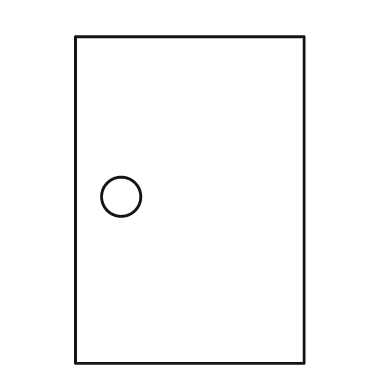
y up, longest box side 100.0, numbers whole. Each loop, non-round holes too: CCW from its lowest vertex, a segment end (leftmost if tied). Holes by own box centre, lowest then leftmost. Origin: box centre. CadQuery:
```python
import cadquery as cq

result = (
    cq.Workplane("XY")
    .moveTo(-35.0, -50.0)
    .lineTo(35.0, -50.0)
    .lineTo(35.0, 50.0)
    .lineTo(-35.0, 50.0)
    .close()
    .moveTo(-21.0, 1.0)
    .circle(6.0)
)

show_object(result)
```